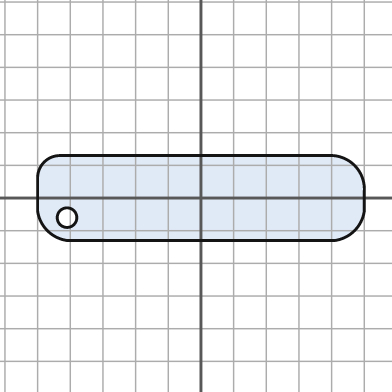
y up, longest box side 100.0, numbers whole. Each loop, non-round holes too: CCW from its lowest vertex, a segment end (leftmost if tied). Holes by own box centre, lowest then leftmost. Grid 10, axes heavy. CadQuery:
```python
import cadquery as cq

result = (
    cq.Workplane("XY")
    .moveTo(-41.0, -13.0)
    .lineTo(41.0, -13.0)
    .threePointArc((47.0, -10.0), (50.0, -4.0))
    .lineTo(50.0, 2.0)
    .threePointArc((47.0, 10.0), (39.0, 13.0))
    .lineTo(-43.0, 13.0)
    .threePointArc((-48.0, 11.0), (-50.0, 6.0))
    .lineTo(-50.0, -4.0)
    .threePointArc((-47.0, -10.0), (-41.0, -13.0))
    .close()
    .moveTo(-41.0, -6.0)
    .circle(3.0)
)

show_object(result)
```